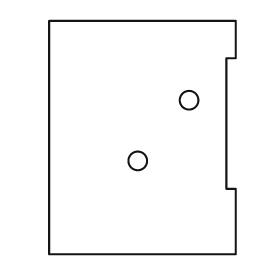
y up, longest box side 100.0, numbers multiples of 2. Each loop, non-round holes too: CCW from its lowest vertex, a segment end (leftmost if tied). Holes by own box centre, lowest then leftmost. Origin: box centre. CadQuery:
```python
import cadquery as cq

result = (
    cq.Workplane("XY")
    .moveTo(-40.0, -50.0)
    .lineTo(40.0, -50.0)
    .lineTo(40.0, -22.0)
    .lineTo(36.0, -22.0)
    .lineTo(36.0, 34.0)
    .lineTo(40.0, 34.0)
    .lineTo(40.0, 50.0)
    .lineTo(-40.0, 50.0)
    .close()
    .moveTo(-2.0, -10.0)
    .circle(4.0)
    .moveTo(20.0, 16.0)
    .circle(4.0)
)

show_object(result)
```